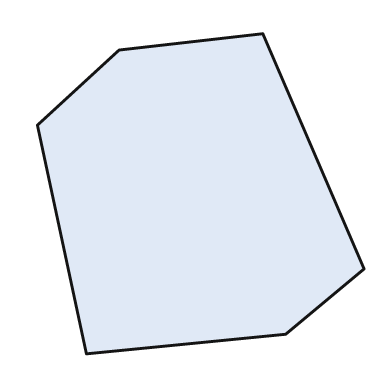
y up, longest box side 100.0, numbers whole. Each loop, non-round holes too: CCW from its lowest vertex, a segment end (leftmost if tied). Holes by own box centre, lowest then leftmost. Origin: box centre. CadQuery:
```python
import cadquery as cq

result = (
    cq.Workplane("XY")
    .moveTo(-35.0, -49.0)
    .lineTo(26.0, -43.0)
    .lineTo(50.0, -23.0)
    .lineTo(19.0, 49.0)
    .lineTo(-25.0, 44.0)
    .lineTo(-50.0, 21.0)
    .close()
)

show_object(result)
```